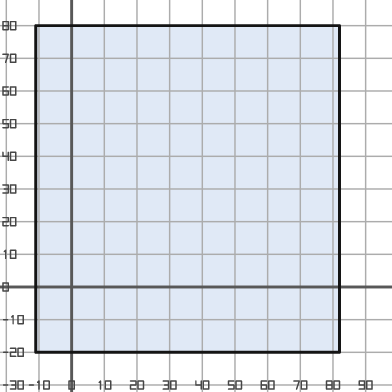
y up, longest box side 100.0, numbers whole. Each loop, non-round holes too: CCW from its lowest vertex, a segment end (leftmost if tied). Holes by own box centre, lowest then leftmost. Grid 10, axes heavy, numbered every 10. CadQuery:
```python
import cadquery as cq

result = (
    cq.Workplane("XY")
    .moveTo(-11.0, -20.0)
    .lineTo(82.0, -20.0)
    .lineTo(82.0, 80.0)
    .lineTo(-11.0, 80.0)
    .close()
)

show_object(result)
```